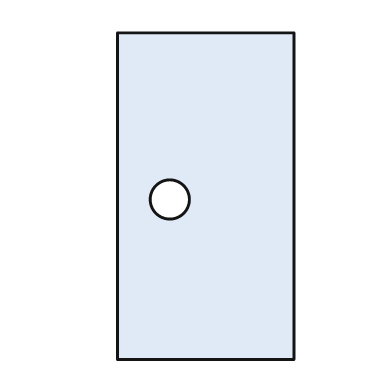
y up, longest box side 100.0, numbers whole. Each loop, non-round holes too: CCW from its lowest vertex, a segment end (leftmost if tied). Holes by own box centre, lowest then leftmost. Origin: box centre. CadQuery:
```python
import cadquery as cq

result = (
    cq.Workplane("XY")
    .moveTo(-27.0, -50.0)
    .lineTo(27.0, -50.0)
    .lineTo(27.0, 50.0)
    .lineTo(-27.0, 50.0)
    .close()
    .moveTo(-11.0, -1.0)
    .circle(6.0)
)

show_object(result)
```